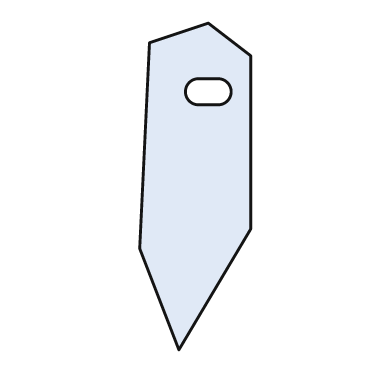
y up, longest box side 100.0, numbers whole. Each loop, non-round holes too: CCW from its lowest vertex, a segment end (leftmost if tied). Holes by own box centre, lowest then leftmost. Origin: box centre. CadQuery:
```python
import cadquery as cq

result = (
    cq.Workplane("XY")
    .moveTo(-5.0, -50.0)
    .lineTo(17.0, -13.0)
    .lineTo(17.0, 40.0)
    .lineTo(4.0, 50.0)
    .lineTo(-14.0, 44.0)
    .lineTo(-17.0, -19.0)
    .close()
    .moveTo(1.0, 25.0)
    .lineTo(7.0, 25.0)
    .threePointArc((11.0, 29.0), (7.0, 33.0))
    .lineTo(1.0, 33.0)
    .threePointArc((-3.0, 29.0), (1.0, 25.0))
    .close()
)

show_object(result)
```